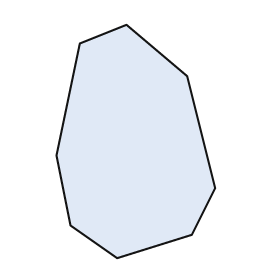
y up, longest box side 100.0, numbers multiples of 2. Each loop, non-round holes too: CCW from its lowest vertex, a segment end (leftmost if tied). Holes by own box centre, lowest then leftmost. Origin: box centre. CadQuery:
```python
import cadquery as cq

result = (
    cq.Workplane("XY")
    .moveTo(-8.0, -50.0)
    .lineTo(24.0, -40.0)
    .lineTo(34.0, -20.0)
    .lineTo(22.0, 28.0)
    .lineTo(-4.0, 50.0)
    .lineTo(-24.0, 42.0)
    .lineTo(-34.0, -6.0)
    .lineTo(-28.0, -36.0)
    .close()
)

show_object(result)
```